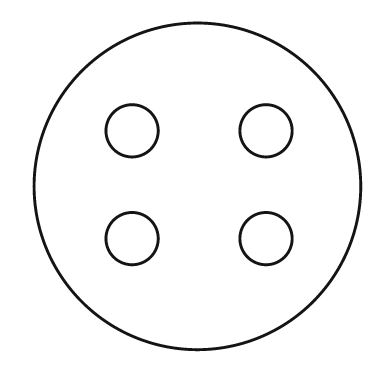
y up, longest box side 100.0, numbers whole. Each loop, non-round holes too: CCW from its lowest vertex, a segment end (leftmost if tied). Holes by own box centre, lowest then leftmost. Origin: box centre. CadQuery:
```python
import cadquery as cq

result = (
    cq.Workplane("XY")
    .moveTo(0.0, 0.0)
    .circle(50.0)
    .moveTo(-20.0, -16.0)
    .circle(8.0)
    .moveTo(21.0, -16.0)
    .circle(8.0)
    .moveTo(-20.0, 17.0)
    .circle(8.0)
    .moveTo(21.0, 17.0)
    .circle(8.0)
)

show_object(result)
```